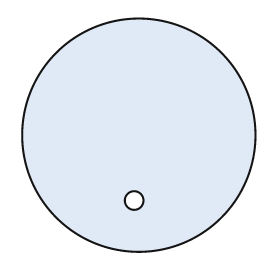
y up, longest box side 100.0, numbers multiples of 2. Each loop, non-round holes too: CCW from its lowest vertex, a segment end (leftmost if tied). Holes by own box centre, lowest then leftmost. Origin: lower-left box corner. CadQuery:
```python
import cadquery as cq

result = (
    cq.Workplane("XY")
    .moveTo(50.0, 50.0)
    .circle(50.0)
    .moveTo(48.0, 22.0)
    .circle(4.0)
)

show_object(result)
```